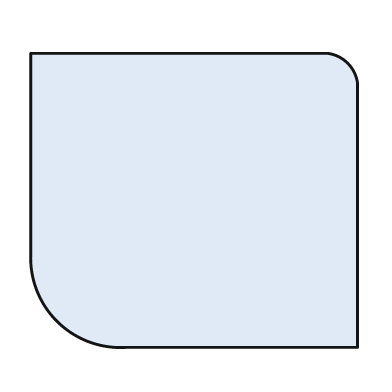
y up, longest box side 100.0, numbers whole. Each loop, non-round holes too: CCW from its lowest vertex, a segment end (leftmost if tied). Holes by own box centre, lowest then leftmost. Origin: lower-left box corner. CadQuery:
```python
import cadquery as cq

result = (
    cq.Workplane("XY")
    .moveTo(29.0, 0.0)
    .lineTo(100.0, 0.0)
    .lineTo(100.0, 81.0)
    .threePointArc((97.0, 87.0), (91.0, 90.0))
    .lineTo(0.0, 90.0)
    .lineTo(0.0, 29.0)
    .threePointArc((8.0, 8.0), (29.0, 0.0))
    .close()
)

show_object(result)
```